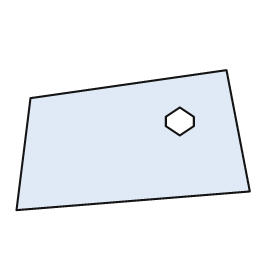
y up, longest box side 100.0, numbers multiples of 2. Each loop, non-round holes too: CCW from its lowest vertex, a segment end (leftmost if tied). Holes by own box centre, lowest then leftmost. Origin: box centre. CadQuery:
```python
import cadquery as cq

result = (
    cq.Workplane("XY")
    .moveTo(-50.0, -30.0)
    .lineTo(50.0, -22.0)
    .lineTo(40.0, 30.0)
    .lineTo(-44.0, 18.0)
    .close()
    .moveTo(20.0, 2.0)
    .lineTo(26.0, 6.0)
    .lineTo(26.0, 10.0)
    .lineTo(20.0, 14.0)
    .lineTo(14.0, 10.0)
    .lineTo(14.0, 6.0)
    .close()
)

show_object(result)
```